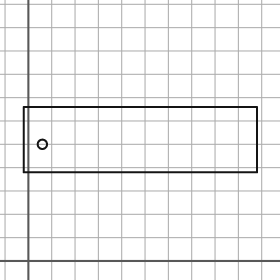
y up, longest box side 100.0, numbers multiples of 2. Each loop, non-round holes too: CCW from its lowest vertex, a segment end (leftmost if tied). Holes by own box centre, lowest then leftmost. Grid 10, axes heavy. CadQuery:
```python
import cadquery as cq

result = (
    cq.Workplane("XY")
    .moveTo(-2.0, 38.0)
    .lineTo(98.0, 38.0)
    .lineTo(98.0, 66.0)
    .lineTo(-2.0, 66.0)
    .close()
    .moveTo(6.0, 50.0)
    .circle(2.0)
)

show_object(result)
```